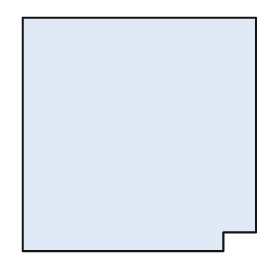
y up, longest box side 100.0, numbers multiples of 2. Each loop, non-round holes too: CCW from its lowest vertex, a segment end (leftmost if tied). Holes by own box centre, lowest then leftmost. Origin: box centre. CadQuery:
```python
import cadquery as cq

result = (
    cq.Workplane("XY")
    .moveTo(-50.0, -50.0)
    .lineTo(36.0, -50.0)
    .lineTo(36.0, -42.0)
    .lineTo(50.0, -42.0)
    .lineTo(50.0, 50.0)
    .lineTo(-50.0, 50.0)
    .close()
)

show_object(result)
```